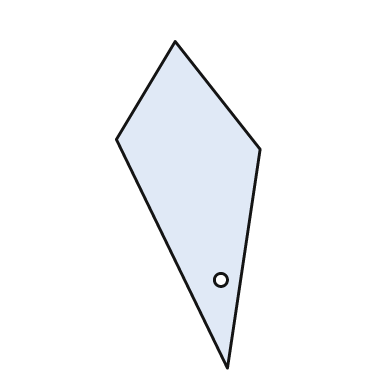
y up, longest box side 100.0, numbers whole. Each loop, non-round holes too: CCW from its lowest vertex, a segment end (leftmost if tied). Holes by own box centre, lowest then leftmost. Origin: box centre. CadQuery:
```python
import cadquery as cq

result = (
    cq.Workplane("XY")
    .moveTo(12.0, -50.0)
    .lineTo(22.0, 17.0)
    .lineTo(-4.0, 50.0)
    .lineTo(-22.0, 20.0)
    .close()
    .moveTo(10.0, -23.0)
    .circle(2.0)
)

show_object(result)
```